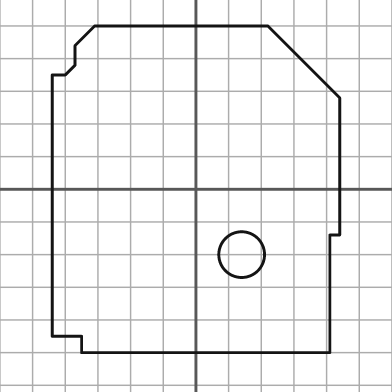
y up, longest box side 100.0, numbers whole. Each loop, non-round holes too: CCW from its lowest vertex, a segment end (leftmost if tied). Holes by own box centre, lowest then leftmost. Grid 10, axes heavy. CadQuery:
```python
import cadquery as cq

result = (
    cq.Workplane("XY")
    .moveTo(-35.0, -50.0)
    .lineTo(41.0, -50.0)
    .lineTo(41.0, -14.0)
    .lineTo(44.0, -14.0)
    .lineTo(44.0, 28.0)
    .lineTo(22.0, 50.0)
    .lineTo(-31.0, 50.0)
    .lineTo(-37.0, 44.0)
    .lineTo(-37.0, 38.0)
    .lineTo(-40.0, 35.0)
    .lineTo(-44.0, 35.0)
    .lineTo(-44.0, -45.0)
    .lineTo(-35.0, -45.0)
    .close()
    .moveTo(14.0, -20.0)
    .circle(7.0)
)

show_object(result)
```